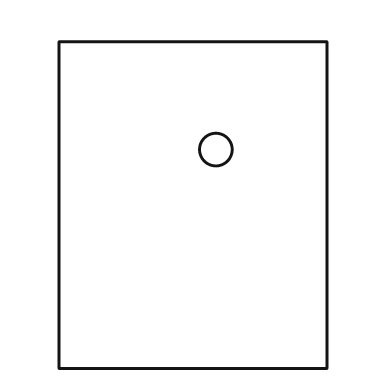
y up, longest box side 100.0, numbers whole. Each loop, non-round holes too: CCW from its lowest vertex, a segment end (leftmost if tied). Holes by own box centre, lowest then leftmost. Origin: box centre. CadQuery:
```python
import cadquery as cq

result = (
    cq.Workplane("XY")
    .moveTo(-41.0, -50.0)
    .lineTo(41.0, -50.0)
    .lineTo(41.0, 50.0)
    .lineTo(-41.0, 50.0)
    .close()
    .moveTo(7.0, 17.0)
    .circle(5.0)
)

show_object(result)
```